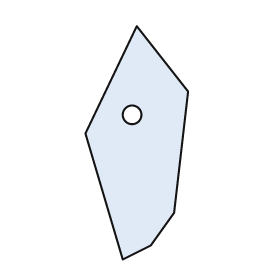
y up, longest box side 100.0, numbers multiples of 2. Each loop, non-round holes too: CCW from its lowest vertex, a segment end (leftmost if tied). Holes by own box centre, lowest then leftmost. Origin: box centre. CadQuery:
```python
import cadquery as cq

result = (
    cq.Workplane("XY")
    .moveTo(-6.0, -50.0)
    .lineTo(6.0, -44.0)
    .lineTo(16.0, -30.0)
    .lineTo(22.0, 22.0)
    .lineTo(0.0, 50.0)
    .lineTo(-22.0, 4.0)
    .close()
    .moveTo(-2.0, 12.0)
    .circle(4.0)
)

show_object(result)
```